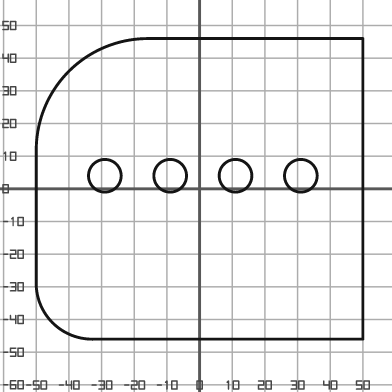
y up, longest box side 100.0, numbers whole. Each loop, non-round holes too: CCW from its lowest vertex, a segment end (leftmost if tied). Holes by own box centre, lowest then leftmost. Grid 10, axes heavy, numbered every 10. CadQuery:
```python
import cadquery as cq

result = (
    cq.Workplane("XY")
    .moveTo(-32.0, -46.0)
    .lineTo(50.0, -46.0)
    .lineTo(50.0, 46.0)
    .lineTo(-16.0, 46.0)
    .threePointArc((-40.0, 36.0), (-50.0, 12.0))
    .lineTo(-50.0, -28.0)
    .threePointArc((-45.0, -41.0), (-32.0, -46.0))
    .close()
    .moveTo(-29.0, 4.0)
    .circle(5.0)
    .moveTo(-9.0, 4.0)
    .circle(5.0)
    .moveTo(11.0, 4.0)
    .circle(5.0)
    .moveTo(31.0, 4.0)
    .circle(5.0)
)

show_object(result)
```